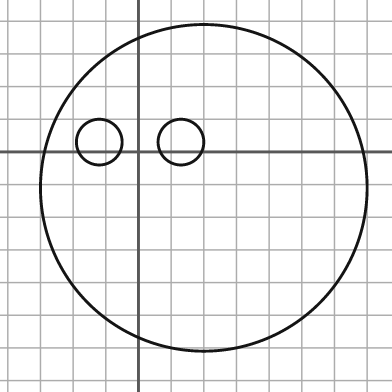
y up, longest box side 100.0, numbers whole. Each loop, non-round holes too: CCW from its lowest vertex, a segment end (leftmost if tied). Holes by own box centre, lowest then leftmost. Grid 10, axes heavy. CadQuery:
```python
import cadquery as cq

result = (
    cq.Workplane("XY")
    .moveTo(20.0, -11.0)
    .circle(50.0)
    .moveTo(-12.0, 3.0)
    .circle(7.0)
    .moveTo(13.0, 3.0)
    .circle(7.0)
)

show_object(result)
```